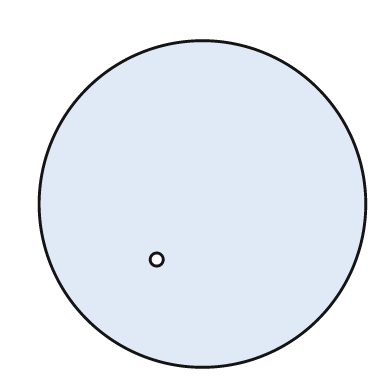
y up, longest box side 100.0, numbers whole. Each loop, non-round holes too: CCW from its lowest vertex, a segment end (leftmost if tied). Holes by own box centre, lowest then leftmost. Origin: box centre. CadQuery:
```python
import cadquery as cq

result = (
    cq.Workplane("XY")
    .moveTo(0.0, 0.0)
    .circle(50.0)
    .moveTo(-14.0, -17.0)
    .circle(2.0)
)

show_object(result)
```